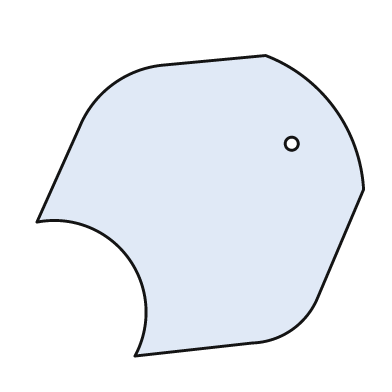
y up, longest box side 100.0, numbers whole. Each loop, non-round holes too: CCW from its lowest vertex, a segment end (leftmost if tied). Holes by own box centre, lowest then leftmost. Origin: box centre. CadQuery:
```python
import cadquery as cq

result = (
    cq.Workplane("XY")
    .moveTo(-20.0, -46.0)
    .lineTo(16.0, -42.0)
    .threePointArc((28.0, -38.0), (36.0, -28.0))
    .lineTo(50.0, 5.0)
    .threePointArc((41.0, 30.0), (20.0, 46.0))
    .lineTo(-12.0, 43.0)
    .threePointArc((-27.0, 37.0), (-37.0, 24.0))
    .lineTo(-50.0, -5.0)
    .threePointArc((-22.0, -16.0), (-20.0, -46.0))
    .close()
    .moveTo(28.0, 19.0)
    .circle(2.0)
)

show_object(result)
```